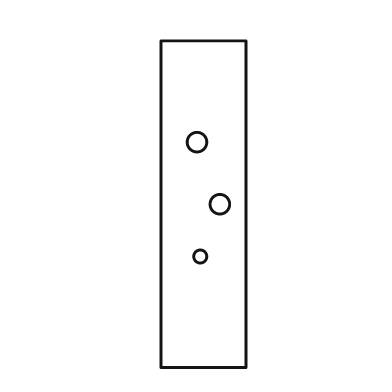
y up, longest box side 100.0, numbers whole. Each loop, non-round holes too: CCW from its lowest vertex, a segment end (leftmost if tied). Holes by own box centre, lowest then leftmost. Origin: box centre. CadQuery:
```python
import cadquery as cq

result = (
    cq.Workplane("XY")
    .moveTo(-13.0, -50.0)
    .lineTo(13.0, -50.0)
    .lineTo(13.0, 50.0)
    .lineTo(-13.0, 50.0)
    .close()
    .moveTo(-1.0, -16.0)
    .circle(2.0)
    .moveTo(5.0, 0.0)
    .circle(3.0)
    .moveTo(-2.0, 19.0)
    .circle(3.0)
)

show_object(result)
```